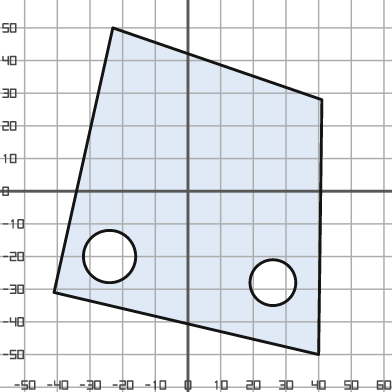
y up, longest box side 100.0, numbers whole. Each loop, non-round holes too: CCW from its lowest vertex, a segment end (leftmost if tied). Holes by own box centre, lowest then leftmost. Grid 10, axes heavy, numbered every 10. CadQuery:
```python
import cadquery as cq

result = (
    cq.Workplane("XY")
    .moveTo(40.0, -50.0)
    .lineTo(41.0, 28.0)
    .lineTo(-23.0, 50.0)
    .lineTo(-41.0, -31.0)
    .close()
    .moveTo(26.0, -28.0)
    .circle(7.0)
    .moveTo(-24.0, -20.0)
    .circle(8.0)
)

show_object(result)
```